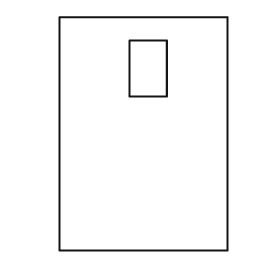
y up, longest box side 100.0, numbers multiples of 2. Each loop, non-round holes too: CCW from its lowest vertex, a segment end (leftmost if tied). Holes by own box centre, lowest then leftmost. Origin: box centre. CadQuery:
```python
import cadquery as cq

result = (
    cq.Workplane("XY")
    .moveTo(-36.0, -50.0)
    .lineTo(36.0, -50.0)
    .lineTo(36.0, 50.0)
    .lineTo(-36.0, 50.0)
    .close()
    .moveTo(-6.0, 16.0)
    .lineTo(10.0, 16.0)
    .lineTo(10.0, 40.0)
    .lineTo(-6.0, 40.0)
    .close()
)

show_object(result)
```